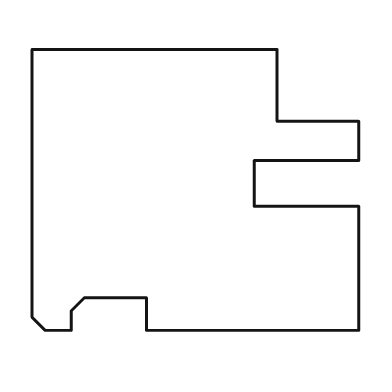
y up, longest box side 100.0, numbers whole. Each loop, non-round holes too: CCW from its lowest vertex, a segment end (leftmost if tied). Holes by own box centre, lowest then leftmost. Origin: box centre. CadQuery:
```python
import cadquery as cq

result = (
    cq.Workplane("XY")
    .moveTo(-46.0, -43.0)
    .lineTo(-38.0, -43.0)
    .lineTo(-38.0, -37.0)
    .lineTo(-34.0, -33.0)
    .lineTo(-15.0, -33.0)
    .lineTo(-15.0, -43.0)
    .lineTo(50.0, -43.0)
    .lineTo(50.0, -5.0)
    .lineTo(18.0, -5.0)
    .lineTo(18.0, 9.0)
    .lineTo(50.0, 9.0)
    .lineTo(50.0, 21.0)
    .lineTo(25.0, 21.0)
    .lineTo(25.0, 43.0)
    .lineTo(-50.0, 43.0)
    .lineTo(-50.0, -39.0)
    .close()
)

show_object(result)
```